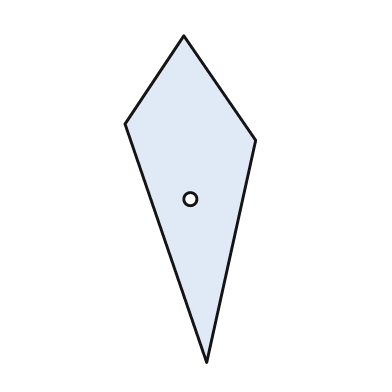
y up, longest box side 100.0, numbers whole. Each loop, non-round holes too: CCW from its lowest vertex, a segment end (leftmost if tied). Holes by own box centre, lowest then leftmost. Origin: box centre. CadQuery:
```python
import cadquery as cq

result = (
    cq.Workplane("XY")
    .moveTo(5.0, -50.0)
    .lineTo(20.0, 18.0)
    .lineTo(-2.0, 50.0)
    .lineTo(-20.0, 23.0)
    .close()
    .moveTo(0.0, 0.0)
    .circle(2.0)
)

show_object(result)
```